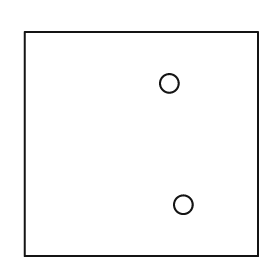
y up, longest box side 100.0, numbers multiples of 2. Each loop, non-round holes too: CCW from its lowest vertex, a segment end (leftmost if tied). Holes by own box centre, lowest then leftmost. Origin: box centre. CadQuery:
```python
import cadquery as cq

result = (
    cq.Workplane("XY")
    .moveTo(-50.0, -48.0)
    .lineTo(50.0, -48.0)
    .lineTo(50.0, 48.0)
    .lineTo(-50.0, 48.0)
    .close()
    .moveTo(18.0, -26.0)
    .circle(4.0)
    .moveTo(12.0, 26.0)
    .circle(4.0)
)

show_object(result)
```